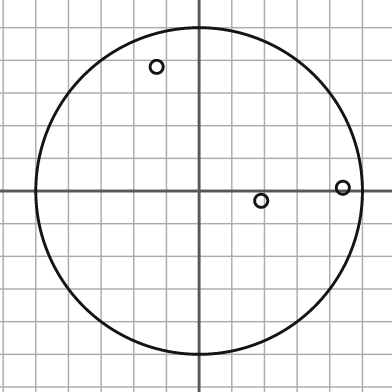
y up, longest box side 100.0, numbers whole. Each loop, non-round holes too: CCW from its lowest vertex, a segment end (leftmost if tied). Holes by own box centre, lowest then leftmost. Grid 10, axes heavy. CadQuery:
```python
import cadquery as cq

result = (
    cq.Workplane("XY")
    .moveTo(0.0, 0.0)
    .circle(50.0)
    .moveTo(19.0, -3.0)
    .circle(2.0)
    .moveTo(44.0, 1.0)
    .circle(2.0)
    .moveTo(-13.0, 38.0)
    .circle(2.0)
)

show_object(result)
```